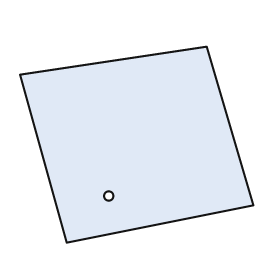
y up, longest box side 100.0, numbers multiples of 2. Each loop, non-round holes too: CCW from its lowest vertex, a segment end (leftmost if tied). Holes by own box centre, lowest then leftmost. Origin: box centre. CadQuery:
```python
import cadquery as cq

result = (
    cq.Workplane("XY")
    .moveTo(-30.0, -42.0)
    .lineTo(50.0, -26.0)
    .lineTo(30.0, 42.0)
    .lineTo(-50.0, 30.0)
    .close()
    .moveTo(-12.0, -22.0)
    .circle(2.0)
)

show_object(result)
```